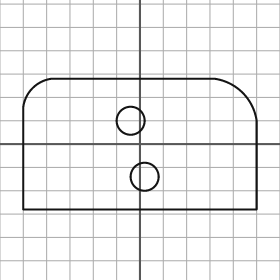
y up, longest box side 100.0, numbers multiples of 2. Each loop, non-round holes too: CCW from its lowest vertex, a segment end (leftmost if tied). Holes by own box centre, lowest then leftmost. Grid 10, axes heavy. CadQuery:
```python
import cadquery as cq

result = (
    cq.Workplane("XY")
    .moveTo(-50.0, -28.0)
    .lineTo(50.0, -28.0)
    .lineTo(50.0, 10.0)
    .threePointArc((44.0, 22.0), (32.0, 28.0))
    .lineTo(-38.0, 28.0)
    .threePointArc((-46.0, 24.0), (-50.0, 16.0))
    .close()
    .moveTo(2.0, -14.0)
    .circle(6.0)
    .moveTo(-4.0, 10.0)
    .circle(6.0)
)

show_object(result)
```